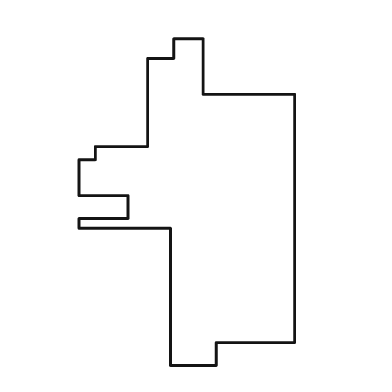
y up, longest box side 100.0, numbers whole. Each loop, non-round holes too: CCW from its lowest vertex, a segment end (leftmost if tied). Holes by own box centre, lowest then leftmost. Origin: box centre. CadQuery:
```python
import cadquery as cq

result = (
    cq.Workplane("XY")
    .moveTo(-5.0, -50.0)
    .lineTo(9.0, -50.0)
    .lineTo(9.0, -43.0)
    .lineTo(33.0, -43.0)
    .lineTo(33.0, 33.0)
    .lineTo(5.0, 33.0)
    .lineTo(5.0, 50.0)
    .lineTo(-4.0, 50.0)
    .lineTo(-4.0, 44.0)
    .lineTo(-12.0, 44.0)
    .lineTo(-12.0, 17.0)
    .lineTo(-28.0, 17.0)
    .lineTo(-28.0, 13.0)
    .lineTo(-33.0, 13.0)
    .lineTo(-33.0, 2.0)
    .lineTo(-18.0, 2.0)
    .lineTo(-18.0, -5.0)
    .lineTo(-33.0, -5.0)
    .lineTo(-33.0, -8.0)
    .lineTo(-5.0, -8.0)
    .close()
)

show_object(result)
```